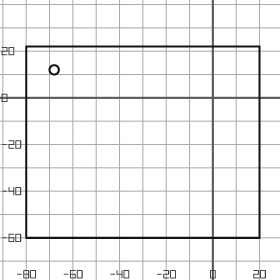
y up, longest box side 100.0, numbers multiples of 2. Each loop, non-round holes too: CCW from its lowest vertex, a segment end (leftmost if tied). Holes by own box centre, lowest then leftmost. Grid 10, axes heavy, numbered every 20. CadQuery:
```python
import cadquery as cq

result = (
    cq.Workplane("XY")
    .moveTo(-80.0, -60.0)
    .lineTo(20.0, -60.0)
    .lineTo(20.0, 22.0)
    .lineTo(-80.0, 22.0)
    .close()
    .moveTo(-68.0, 12.0)
    .circle(2.0)
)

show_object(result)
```